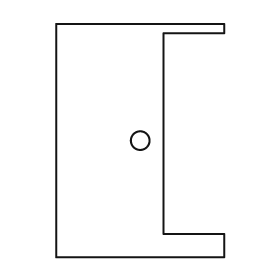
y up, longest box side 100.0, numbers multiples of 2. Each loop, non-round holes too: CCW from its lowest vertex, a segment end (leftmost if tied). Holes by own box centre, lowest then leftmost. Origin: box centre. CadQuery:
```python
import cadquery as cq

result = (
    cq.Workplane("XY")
    .moveTo(-36.0, -50.0)
    .lineTo(36.0, -50.0)
    .lineTo(36.0, -40.0)
    .lineTo(10.0, -40.0)
    .lineTo(10.0, 46.0)
    .lineTo(36.0, 46.0)
    .lineTo(36.0, 50.0)
    .lineTo(-36.0, 50.0)
    .close()
    .moveTo(0.0, 0.0)
    .circle(4.0)
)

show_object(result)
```